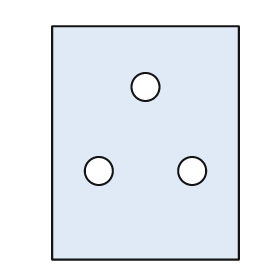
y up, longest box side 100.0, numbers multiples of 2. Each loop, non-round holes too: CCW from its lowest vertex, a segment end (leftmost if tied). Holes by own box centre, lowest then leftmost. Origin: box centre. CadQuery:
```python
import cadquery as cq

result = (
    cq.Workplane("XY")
    .moveTo(-40.0, -50.0)
    .lineTo(40.0, -50.0)
    .lineTo(40.0, 50.0)
    .lineTo(-40.0, 50.0)
    .close()
    .moveTo(-20.0, -12.0)
    .circle(6.0)
    .moveTo(20.0, -12.0)
    .circle(6.0)
    .moveTo(0.0, 24.0)
    .circle(6.0)
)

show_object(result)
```